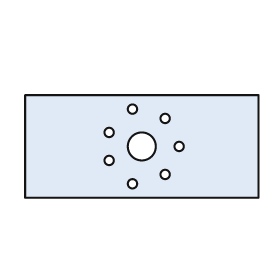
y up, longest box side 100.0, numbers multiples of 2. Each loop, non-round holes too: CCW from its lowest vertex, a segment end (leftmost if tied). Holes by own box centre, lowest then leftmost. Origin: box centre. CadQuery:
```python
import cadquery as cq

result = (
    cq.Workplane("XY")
    .moveTo(-50.0, -22.0)
    .lineTo(50.0, -22.0)
    .lineTo(50.0, 22.0)
    .lineTo(-50.0, 22.0)
    .close()
    .moveTo(-4.0, -16.0)
    .circle(2.0)
    .moveTo(10.0, -12.0)
    .circle(2.0)
    .moveTo(-14.0, -6.0)
    .circle(2.0)
    .moveTo(0.0, 0.0)
    .circle(6.0)
    .moveTo(16.0, 0.0)
    .circle(2.0)
    .moveTo(-14.0, 6.0)
    .circle(2.0)
    .moveTo(10.0, 12.0)
    .circle(2.0)
    .moveTo(-4.0, 16.0)
    .circle(2.0)
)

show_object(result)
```